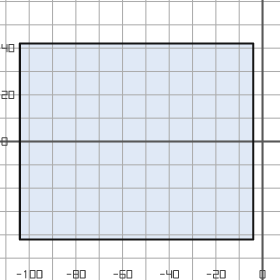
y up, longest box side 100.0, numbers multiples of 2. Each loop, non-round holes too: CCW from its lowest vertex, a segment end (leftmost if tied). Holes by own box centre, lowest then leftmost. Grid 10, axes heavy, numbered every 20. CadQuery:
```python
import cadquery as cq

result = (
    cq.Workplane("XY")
    .moveTo(-104.0, -42.0)
    .lineTo(-4.0, -42.0)
    .lineTo(-4.0, 42.0)
    .lineTo(-104.0, 42.0)
    .close()
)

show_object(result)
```